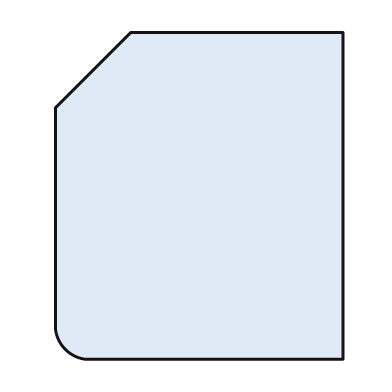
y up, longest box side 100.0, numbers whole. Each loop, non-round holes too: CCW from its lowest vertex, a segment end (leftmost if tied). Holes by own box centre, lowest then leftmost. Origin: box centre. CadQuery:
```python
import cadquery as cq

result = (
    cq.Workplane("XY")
    .moveTo(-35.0, -50.0)
    .lineTo(44.0, -50.0)
    .lineTo(44.0, 50.0)
    .lineTo(-21.0, 50.0)
    .lineTo(-44.0, 27.0)
    .lineTo(-44.0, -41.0)
    .threePointArc((-41.0, -47.0), (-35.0, -50.0))
    .close()
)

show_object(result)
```